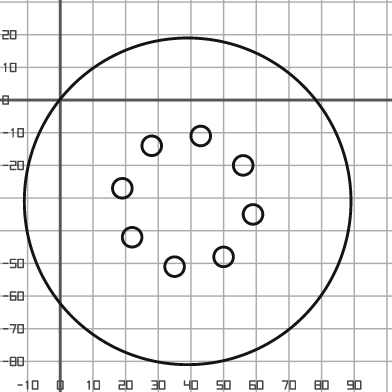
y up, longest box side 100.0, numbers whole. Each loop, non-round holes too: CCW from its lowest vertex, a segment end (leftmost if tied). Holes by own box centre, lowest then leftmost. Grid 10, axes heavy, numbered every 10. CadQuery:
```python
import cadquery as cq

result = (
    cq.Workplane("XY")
    .moveTo(39.0, -31.0)
    .circle(50.0)
    .moveTo(35.0, -51.0)
    .circle(3.0)
    .moveTo(50.0, -48.0)
    .circle(3.0)
    .moveTo(22.0, -42.0)
    .circle(3.0)
    .moveTo(59.0, -35.0)
    .circle(3.0)
    .moveTo(19.0, -27.0)
    .circle(3.0)
    .moveTo(56.0, -20.0)
    .circle(3.0)
    .moveTo(28.0, -14.0)
    .circle(3.0)
    .moveTo(43.0, -11.0)
    .circle(3.0)
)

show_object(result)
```